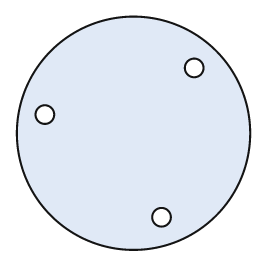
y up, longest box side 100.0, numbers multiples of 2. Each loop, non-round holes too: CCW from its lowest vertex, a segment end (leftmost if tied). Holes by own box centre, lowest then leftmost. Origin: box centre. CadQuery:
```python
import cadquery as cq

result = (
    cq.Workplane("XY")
    .moveTo(0.0, 0.0)
    .circle(50.0)
    .moveTo(12.0, -36.0)
    .circle(4.0)
    .moveTo(-38.0, 8.0)
    .circle(4.0)
    .moveTo(26.0, 28.0)
    .circle(4.0)
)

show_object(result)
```